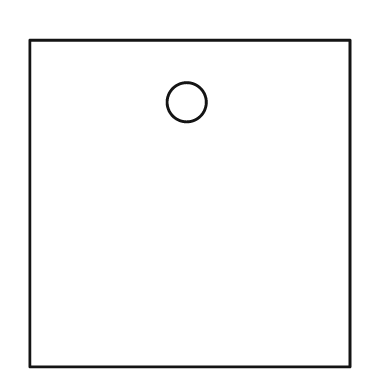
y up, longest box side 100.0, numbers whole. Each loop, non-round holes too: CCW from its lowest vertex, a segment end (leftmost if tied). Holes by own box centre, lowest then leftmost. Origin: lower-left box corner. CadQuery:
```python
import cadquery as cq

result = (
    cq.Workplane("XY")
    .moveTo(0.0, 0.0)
    .lineTo(98.0, 0.0)
    .lineTo(98.0, 100.0)
    .lineTo(0.0, 100.0)
    .close()
    .moveTo(48.0, 81.0)
    .circle(6.0)
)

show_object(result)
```